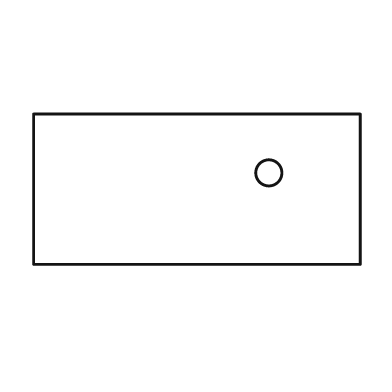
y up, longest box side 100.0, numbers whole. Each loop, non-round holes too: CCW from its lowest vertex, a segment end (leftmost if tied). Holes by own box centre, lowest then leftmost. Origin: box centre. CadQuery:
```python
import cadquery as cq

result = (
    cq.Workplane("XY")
    .moveTo(-50.0, -23.0)
    .lineTo(50.0, -23.0)
    .lineTo(50.0, 23.0)
    .lineTo(-50.0, 23.0)
    .close()
    .moveTo(22.0, 5.0)
    .circle(4.0)
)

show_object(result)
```